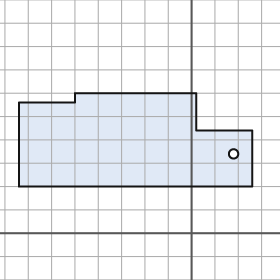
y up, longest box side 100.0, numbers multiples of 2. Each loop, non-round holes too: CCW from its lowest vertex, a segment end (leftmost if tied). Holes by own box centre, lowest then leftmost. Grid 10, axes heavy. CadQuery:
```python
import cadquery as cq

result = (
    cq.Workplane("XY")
    .moveTo(-74.0, 20.0)
    .lineTo(26.0, 20.0)
    .lineTo(26.0, 44.0)
    .lineTo(2.0, 44.0)
    .lineTo(2.0, 60.0)
    .lineTo(-50.0, 60.0)
    .lineTo(-50.0, 56.0)
    .lineTo(-74.0, 56.0)
    .close()
    .moveTo(18.0, 34.0)
    .circle(2.0)
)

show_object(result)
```